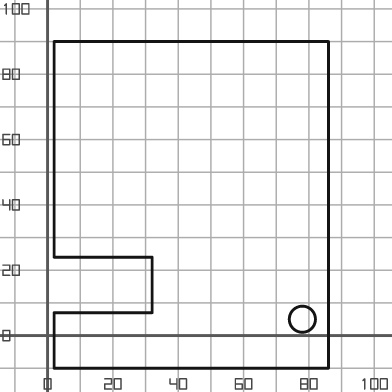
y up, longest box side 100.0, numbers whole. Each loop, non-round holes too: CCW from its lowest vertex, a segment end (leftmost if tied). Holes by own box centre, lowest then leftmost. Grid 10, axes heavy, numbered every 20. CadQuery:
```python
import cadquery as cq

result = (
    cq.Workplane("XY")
    .moveTo(2.0, -10.0)
    .lineTo(86.0, -10.0)
    .lineTo(86.0, 90.0)
    .lineTo(2.0, 90.0)
    .lineTo(2.0, 24.0)
    .lineTo(32.0, 24.0)
    .lineTo(32.0, 7.0)
    .lineTo(2.0, 7.0)
    .close()
    .moveTo(78.0, 5.0)
    .circle(4.0)
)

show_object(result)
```